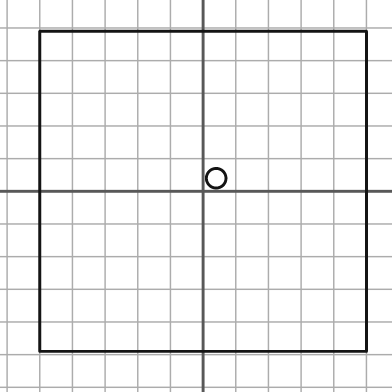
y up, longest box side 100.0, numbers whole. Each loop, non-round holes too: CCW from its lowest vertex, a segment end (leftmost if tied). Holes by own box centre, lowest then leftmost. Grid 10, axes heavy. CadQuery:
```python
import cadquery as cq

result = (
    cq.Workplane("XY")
    .moveTo(-50.0, -49.0)
    .lineTo(50.0, -49.0)
    .lineTo(50.0, 49.0)
    .lineTo(-50.0, 49.0)
    .close()
    .moveTo(4.0, 4.0)
    .circle(3.0)
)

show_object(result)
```